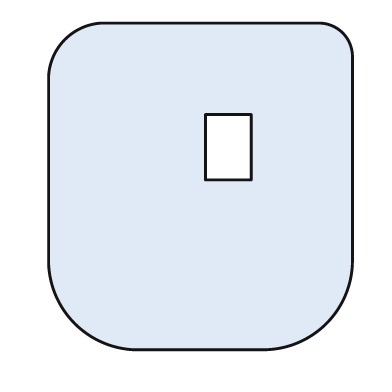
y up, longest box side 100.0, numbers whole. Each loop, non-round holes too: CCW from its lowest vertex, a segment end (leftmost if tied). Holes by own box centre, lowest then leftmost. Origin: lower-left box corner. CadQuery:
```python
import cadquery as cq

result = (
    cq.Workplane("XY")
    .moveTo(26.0, 0.0)
    .lineTo(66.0, 0.0)
    .threePointArc((85.0, 8.0), (93.0, 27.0))
    .lineTo(93.0, 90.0)
    .threePointArc((90.0, 97.0), (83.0, 100.0))
    .lineTo(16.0, 100.0)
    .threePointArc((5.0, 95.0), (0.0, 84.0))
    .lineTo(0.0, 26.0)
    .threePointArc((8.0, 8.0), (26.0, 0.0))
    .close()
    .moveTo(48.0, 52.0)
    .lineTo(62.0, 52.0)
    .lineTo(62.0, 72.0)
    .lineTo(48.0, 72.0)
    .close()
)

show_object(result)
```